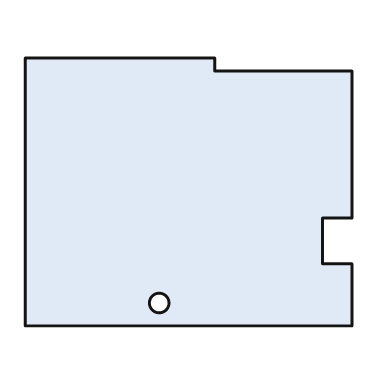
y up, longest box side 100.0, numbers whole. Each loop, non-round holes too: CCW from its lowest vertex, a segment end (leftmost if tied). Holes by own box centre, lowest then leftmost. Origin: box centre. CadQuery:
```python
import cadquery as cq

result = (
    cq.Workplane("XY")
    .moveTo(-50.0, -41.0)
    .lineTo(50.0, -41.0)
    .lineTo(50.0, -22.0)
    .lineTo(41.0, -22.0)
    .lineTo(41.0, -8.0)
    .lineTo(50.0, -8.0)
    .lineTo(50.0, 37.0)
    .lineTo(8.0, 37.0)
    .lineTo(8.0, 41.0)
    .lineTo(-50.0, 41.0)
    .close()
    .moveTo(-9.0, -34.0)
    .circle(3.0)
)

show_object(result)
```